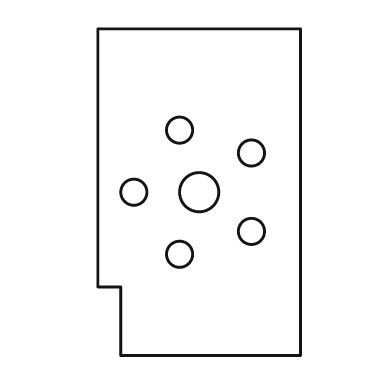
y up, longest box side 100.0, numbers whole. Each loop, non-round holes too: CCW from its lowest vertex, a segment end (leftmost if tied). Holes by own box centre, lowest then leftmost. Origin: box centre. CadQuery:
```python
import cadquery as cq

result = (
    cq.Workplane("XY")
    .moveTo(-24.0, -50.0)
    .lineTo(31.0, -50.0)
    .lineTo(31.0, 50.0)
    .lineTo(-31.0, 50.0)
    .lineTo(-31.0, -29.0)
    .lineTo(-24.0, -29.0)
    .close()
    .moveTo(-6.0, -19.0)
    .circle(4.0)
    .moveTo(16.0, -12.0)
    .circle(4.0)
    .moveTo(-20.0, 0.0)
    .circle(4.0)
    .moveTo(0.0, 0.0)
    .circle(6.0)
    .moveTo(16.0, 12.0)
    .circle(4.0)
    .moveTo(-6.0, 19.0)
    .circle(4.0)
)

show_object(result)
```